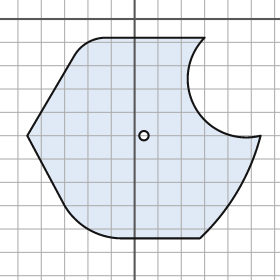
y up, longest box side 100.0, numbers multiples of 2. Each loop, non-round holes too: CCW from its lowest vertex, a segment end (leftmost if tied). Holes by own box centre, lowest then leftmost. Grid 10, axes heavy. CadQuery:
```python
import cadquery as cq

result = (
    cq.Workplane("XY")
    .moveTo(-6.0, -94.0)
    .lineTo(28.0, -94.0)
    .threePointArc((44.0, -74.0), (54.0, -50.0))
    .threePointArc((26.0, -38.0), (30.0, -8.0))
    .lineTo(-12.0, -8.0)
    .threePointArc((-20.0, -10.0), (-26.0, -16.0))
    .lineTo(-46.0, -50.0)
    .lineTo(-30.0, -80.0)
    .threePointArc((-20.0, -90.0), (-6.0, -94.0))
    .close()
    .moveTo(4.0, -50.0)
    .circle(2.0)
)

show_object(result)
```